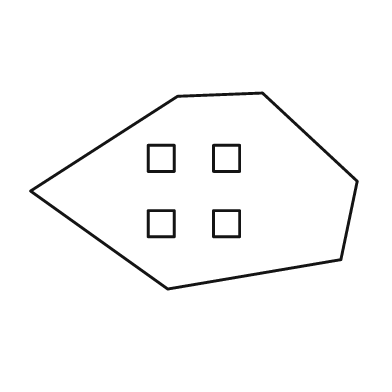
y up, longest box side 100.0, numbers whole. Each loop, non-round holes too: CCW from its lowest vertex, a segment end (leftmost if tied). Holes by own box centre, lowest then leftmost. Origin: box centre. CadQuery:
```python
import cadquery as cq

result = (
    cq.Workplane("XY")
    .moveTo(-8.0, -30.0)
    .lineTo(45.0, -21.0)
    .lineTo(50.0, 3.0)
    .lineTo(21.0, 30.0)
    .lineTo(-5.0, 29.0)
    .lineTo(-50.0, 0.0)
    .close()
    .moveTo(-14.0, -14.0)
    .lineTo(-6.0, -14.0)
    .lineTo(-6.0, -6.0)
    .lineTo(-14.0, -6.0)
    .close()
    .moveTo(6.0, -14.0)
    .lineTo(14.0, -14.0)
    .lineTo(14.0, -6.0)
    .lineTo(6.0, -6.0)
    .close()
    .moveTo(-14.0, 6.0)
    .lineTo(-6.0, 6.0)
    .lineTo(-6.0, 14.0)
    .lineTo(-14.0, 14.0)
    .close()
    .moveTo(6.0, 6.0)
    .lineTo(14.0, 6.0)
    .lineTo(14.0, 14.0)
    .lineTo(6.0, 14.0)
    .close()
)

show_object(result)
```